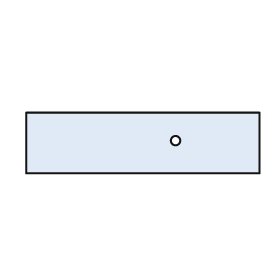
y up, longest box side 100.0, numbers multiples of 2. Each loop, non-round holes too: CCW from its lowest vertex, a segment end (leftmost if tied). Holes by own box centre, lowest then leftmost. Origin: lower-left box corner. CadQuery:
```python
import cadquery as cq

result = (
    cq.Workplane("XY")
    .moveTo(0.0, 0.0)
    .lineTo(100.0, 0.0)
    .lineTo(100.0, 26.0)
    .lineTo(0.0, 26.0)
    .close()
    .moveTo(64.0, 14.0)
    .circle(2.0)
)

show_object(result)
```